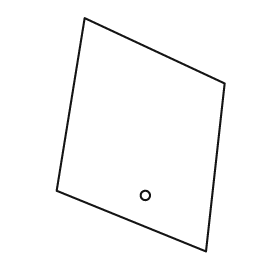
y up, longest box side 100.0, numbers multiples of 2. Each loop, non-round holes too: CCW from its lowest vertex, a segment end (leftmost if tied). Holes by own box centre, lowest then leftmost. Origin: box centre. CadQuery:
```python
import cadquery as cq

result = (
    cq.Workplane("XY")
    .moveTo(28.0, -50.0)
    .lineTo(36.0, 22.0)
    .lineTo(-24.0, 50.0)
    .lineTo(-36.0, -24.0)
    .close()
    .moveTo(2.0, -26.0)
    .circle(2.0)
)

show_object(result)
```